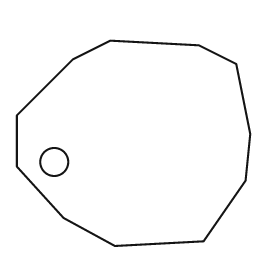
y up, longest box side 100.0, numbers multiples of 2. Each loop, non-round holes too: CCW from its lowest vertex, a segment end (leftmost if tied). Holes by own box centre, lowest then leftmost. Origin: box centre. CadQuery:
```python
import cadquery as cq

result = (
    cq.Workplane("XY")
    .moveTo(-8.0, -44.0)
    .lineTo(30.0, -42.0)
    .lineTo(48.0, -16.0)
    .lineTo(50.0, 4.0)
    .lineTo(44.0, 34.0)
    .lineTo(28.0, 42.0)
    .lineTo(-10.0, 44.0)
    .lineTo(-26.0, 36.0)
    .lineTo(-50.0, 12.0)
    .lineTo(-50.0, -10.0)
    .lineTo(-30.0, -32.0)
    .close()
    .moveTo(-34.0, -8.0)
    .circle(6.0)
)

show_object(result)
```